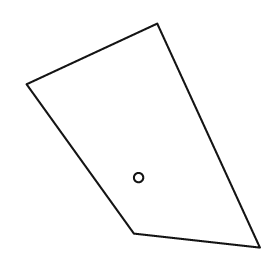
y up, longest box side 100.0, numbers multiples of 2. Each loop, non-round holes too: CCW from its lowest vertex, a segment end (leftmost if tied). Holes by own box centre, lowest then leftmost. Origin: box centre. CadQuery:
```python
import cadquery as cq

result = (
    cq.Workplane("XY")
    .moveTo(50.0, -48.0)
    .lineTo(6.0, 48.0)
    .lineTo(-50.0, 22.0)
    .lineTo(-4.0, -42.0)
    .close()
    .moveTo(-2.0, -18.0)
    .circle(2.0)
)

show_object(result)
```